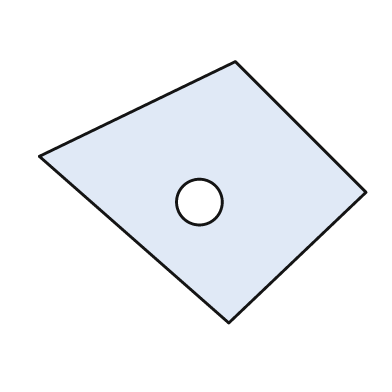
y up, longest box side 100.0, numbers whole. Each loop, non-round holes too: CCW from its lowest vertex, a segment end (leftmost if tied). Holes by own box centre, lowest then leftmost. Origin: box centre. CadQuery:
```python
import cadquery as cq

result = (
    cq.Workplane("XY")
    .moveTo(8.0, -40.0)
    .lineTo(50.0, 0.0)
    .lineTo(10.0, 40.0)
    .lineTo(-50.0, 11.0)
    .close()
    .moveTo(-1.0, -3.0)
    .circle(7.0)
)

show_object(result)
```